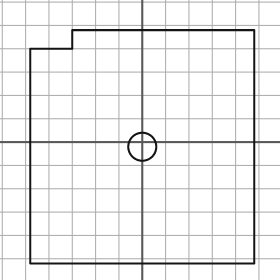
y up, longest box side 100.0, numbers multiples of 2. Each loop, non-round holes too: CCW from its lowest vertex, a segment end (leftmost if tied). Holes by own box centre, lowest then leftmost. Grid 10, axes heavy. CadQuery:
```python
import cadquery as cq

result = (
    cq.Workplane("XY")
    .moveTo(-48.0, -52.0)
    .lineTo(48.0, -52.0)
    .lineTo(48.0, 48.0)
    .lineTo(-30.0, 48.0)
    .lineTo(-30.0, 40.0)
    .lineTo(-48.0, 40.0)
    .close()
    .moveTo(0.0, -2.0)
    .circle(6.0)
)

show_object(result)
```